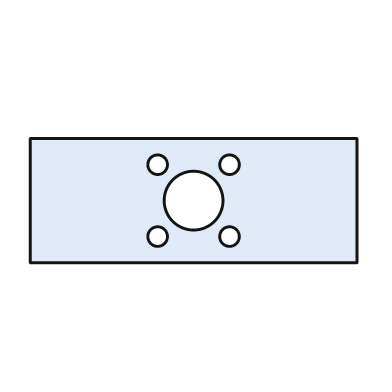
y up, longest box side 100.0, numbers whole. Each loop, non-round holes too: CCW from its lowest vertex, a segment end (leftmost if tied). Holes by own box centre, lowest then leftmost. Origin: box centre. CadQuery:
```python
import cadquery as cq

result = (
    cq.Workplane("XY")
    .moveTo(-50.0, -19.0)
    .lineTo(50.0, -19.0)
    .lineTo(50.0, 19.0)
    .lineTo(-50.0, 19.0)
    .close()
    .moveTo(-11.0, -11.0)
    .circle(3.0)
    .moveTo(11.0, -11.0)
    .circle(3.0)
    .moveTo(0.0, 0.0)
    .circle(9.0)
    .moveTo(-11.0, 11.0)
    .circle(3.0)
    .moveTo(11.0, 11.0)
    .circle(3.0)
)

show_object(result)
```